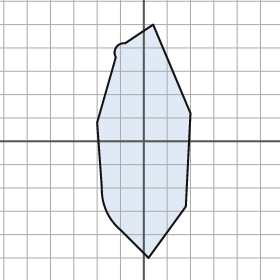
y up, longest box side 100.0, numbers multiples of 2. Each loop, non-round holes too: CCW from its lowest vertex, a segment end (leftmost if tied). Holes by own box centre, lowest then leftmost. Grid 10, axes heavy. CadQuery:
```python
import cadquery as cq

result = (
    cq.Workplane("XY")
    .moveTo(2.0, -50.0)
    .lineTo(18.0, -28.0)
    .lineTo(20.0, 12.0)
    .lineTo(4.0, 50.0)
    .lineTo(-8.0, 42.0)
    .threePointArc((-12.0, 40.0), (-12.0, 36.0))
    .lineTo(-20.0, 8.0)
    .lineTo(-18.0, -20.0)
    .threePointArc((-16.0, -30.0), (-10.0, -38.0))
    .close()
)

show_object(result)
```